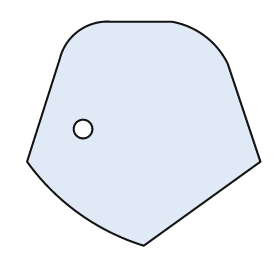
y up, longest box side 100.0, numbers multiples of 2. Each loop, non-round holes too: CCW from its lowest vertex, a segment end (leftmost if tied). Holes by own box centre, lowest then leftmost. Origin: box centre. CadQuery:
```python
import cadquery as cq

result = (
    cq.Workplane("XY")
    .moveTo(0.0, -48.0)
    .lineTo(50.0, -12.0)
    .lineTo(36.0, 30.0)
    .threePointArc((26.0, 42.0), (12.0, 48.0))
    .lineTo(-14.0, 48.0)
    .threePointArc((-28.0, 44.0), (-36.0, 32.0))
    .lineTo(-50.0, -12.0)
    .threePointArc((-28.0, -34.0), (0.0, -48.0))
    .close()
    .moveTo(-26.0, 2.0)
    .circle(4.0)
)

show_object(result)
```